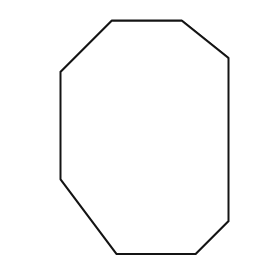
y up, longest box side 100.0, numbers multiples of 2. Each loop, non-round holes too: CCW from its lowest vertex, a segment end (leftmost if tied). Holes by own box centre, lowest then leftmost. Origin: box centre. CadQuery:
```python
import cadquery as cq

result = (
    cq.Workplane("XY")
    .moveTo(-12.0, -50.0)
    .lineTo(22.0, -50.0)
    .lineTo(36.0, -36.0)
    .lineTo(36.0, 34.0)
    .lineTo(16.0, 50.0)
    .lineTo(-14.0, 50.0)
    .lineTo(-36.0, 28.0)
    .lineTo(-36.0, -18.0)
    .close()
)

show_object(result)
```